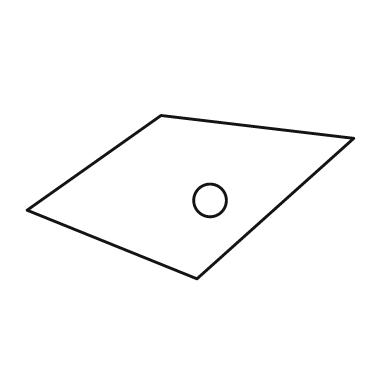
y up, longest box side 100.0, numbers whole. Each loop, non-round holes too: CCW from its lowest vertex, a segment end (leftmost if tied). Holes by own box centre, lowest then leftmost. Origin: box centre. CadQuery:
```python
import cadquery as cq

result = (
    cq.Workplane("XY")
    .moveTo(2.0, -25.0)
    .lineTo(50.0, 18.0)
    .lineTo(-9.0, 25.0)
    .lineTo(-50.0, -4.0)
    .close()
    .moveTo(6.0, -1.0)
    .circle(5.0)
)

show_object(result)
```